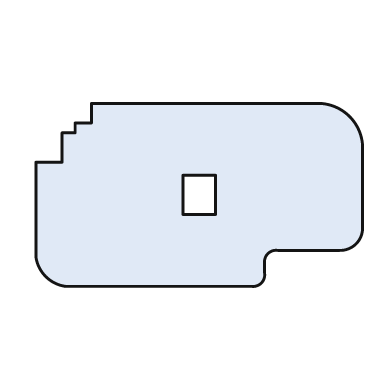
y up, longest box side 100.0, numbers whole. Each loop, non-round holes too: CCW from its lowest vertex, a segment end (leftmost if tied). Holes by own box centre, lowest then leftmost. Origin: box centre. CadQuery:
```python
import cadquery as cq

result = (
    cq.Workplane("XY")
    .moveTo(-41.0, -28.0)
    .lineTo(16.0, -28.0)
    .threePointArc((19.0, -27.0), (20.0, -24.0))
    .lineTo(20.0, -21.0)
    .threePointArc((21.0, -18.0), (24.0, -17.0))
    .lineTo(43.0, -17.0)
    .threePointArc((48.0, -15.0), (50.0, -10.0))
    .lineTo(50.0, 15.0)
    .threePointArc((46.0, 24.0), (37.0, 28.0))
    .lineTo(-33.0, 28.0)
    .lineTo(-33.0, 22.0)
    .lineTo(-38.0, 22.0)
    .lineTo(-38.0, 19.0)
    .lineTo(-42.0, 19.0)
    .lineTo(-42.0, 10.0)
    .lineTo(-50.0, 10.0)
    .lineTo(-50.0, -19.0)
    .threePointArc((-47.0, -25.0), (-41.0, -28.0))
    .close()
    .moveTo(-5.0, -6.0)
    .lineTo(5.0, -6.0)
    .lineTo(5.0, 6.0)
    .lineTo(-5.0, 6.0)
    .close()
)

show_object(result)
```